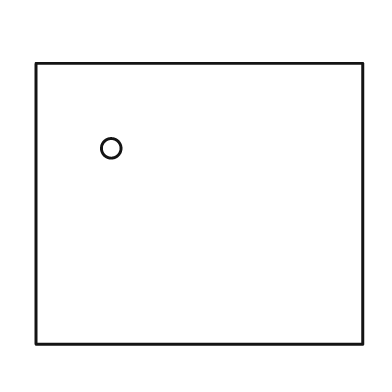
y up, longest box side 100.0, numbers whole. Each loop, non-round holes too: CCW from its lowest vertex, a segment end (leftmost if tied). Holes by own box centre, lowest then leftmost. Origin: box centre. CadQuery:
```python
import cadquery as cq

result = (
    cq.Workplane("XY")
    .moveTo(-50.0, -43.0)
    .lineTo(50.0, -43.0)
    .lineTo(50.0, 43.0)
    .lineTo(-50.0, 43.0)
    .close()
    .moveTo(-27.0, 17.0)
    .circle(3.0)
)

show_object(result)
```